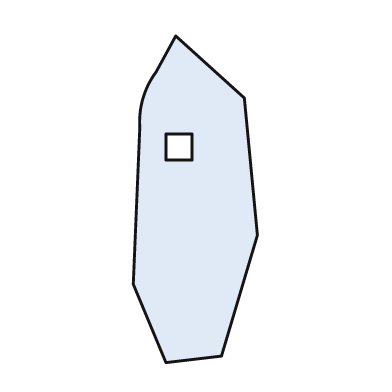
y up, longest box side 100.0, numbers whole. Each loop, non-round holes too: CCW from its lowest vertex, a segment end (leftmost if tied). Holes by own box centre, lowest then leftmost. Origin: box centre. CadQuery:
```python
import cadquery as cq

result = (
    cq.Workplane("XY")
    .moveTo(-9.0, -50.0)
    .lineTo(8.0, -48.0)
    .lineTo(19.0, -11.0)
    .lineTo(15.0, 31.0)
    .lineTo(-6.0, 50.0)
    .lineTo(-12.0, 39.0)
    .threePointArc((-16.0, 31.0), (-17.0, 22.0))
    .lineTo(-19.0, -26.0)
    .close()
    .moveTo(-9.0, 12.0)
    .lineTo(-1.0, 12.0)
    .lineTo(-1.0, 20.0)
    .lineTo(-9.0, 20.0)
    .close()
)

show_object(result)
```